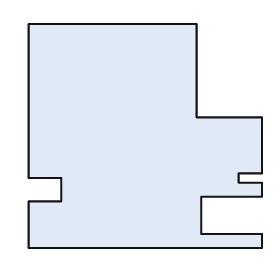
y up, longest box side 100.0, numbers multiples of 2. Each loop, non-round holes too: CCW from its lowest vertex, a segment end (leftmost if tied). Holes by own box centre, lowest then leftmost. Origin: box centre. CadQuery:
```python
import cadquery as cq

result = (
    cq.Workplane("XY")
    .moveTo(-50.0, -48.0)
    .lineTo(50.0, -48.0)
    .lineTo(50.0, -42.0)
    .lineTo(24.0, -42.0)
    .lineTo(24.0, -26.0)
    .lineTo(50.0, -26.0)
    .lineTo(50.0, -20.0)
    .lineTo(40.0, -20.0)
    .lineTo(40.0, -16.0)
    .lineTo(50.0, -16.0)
    .lineTo(50.0, 8.0)
    .lineTo(22.0, 8.0)
    .lineTo(22.0, 48.0)
    .lineTo(-50.0, 48.0)
    .lineTo(-50.0, -18.0)
    .lineTo(-36.0, -18.0)
    .lineTo(-36.0, -28.0)
    .lineTo(-50.0, -28.0)
    .close()
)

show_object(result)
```